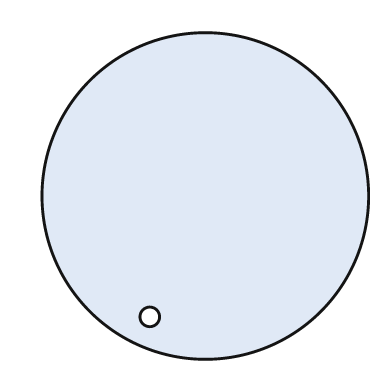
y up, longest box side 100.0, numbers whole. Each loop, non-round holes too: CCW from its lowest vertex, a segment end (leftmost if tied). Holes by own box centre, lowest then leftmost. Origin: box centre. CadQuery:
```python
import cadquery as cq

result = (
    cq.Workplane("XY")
    .moveTo(0.0, 0.0)
    .circle(50.0)
    .moveTo(-17.0, -37.0)
    .circle(3.0)
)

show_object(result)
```